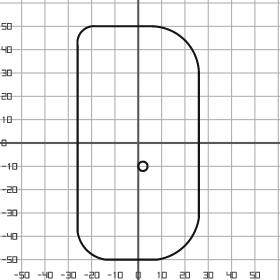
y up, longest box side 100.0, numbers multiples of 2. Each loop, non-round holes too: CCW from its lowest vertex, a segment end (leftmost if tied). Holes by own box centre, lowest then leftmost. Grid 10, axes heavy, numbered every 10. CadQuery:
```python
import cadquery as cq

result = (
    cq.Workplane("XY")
    .moveTo(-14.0, -50.0)
    .lineTo(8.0, -50.0)
    .threePointArc((20.0, -44.0), (26.0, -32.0))
    .lineTo(26.0, 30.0)
    .threePointArc((20.0, 44.0), (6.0, 50.0))
    .lineTo(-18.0, 50.0)
    .threePointArc((-24.0, 48.0), (-26.0, 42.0))
    .lineTo(-26.0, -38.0)
    .threePointArc((-22.0, -46.0), (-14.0, -50.0))
    .close()
    .moveTo(2.0, -10.0)
    .circle(2.0)
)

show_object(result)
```